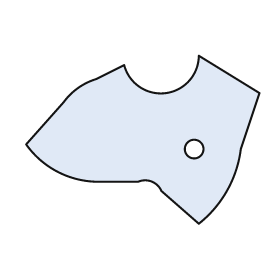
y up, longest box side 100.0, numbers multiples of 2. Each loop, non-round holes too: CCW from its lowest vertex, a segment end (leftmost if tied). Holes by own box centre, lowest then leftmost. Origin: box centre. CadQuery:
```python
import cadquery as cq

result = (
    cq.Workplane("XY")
    .moveTo(24.0, -36.0)
    .threePointArc((36.0, -22.0), (42.0, -4.0))
    .lineTo(50.0, 20.0)
    .lineTo(24.0, 36.0)
    .threePointArc((10.0, 20.0), (-8.0, 32.0))
    .lineTo(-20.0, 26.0)
    .threePointArc((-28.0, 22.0), (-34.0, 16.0))
    .lineTo(-50.0, -2.0)
    .threePointArc((-36.0, -14.0), (-18.0, -18.0))
    .lineTo(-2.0, -18.0)
    .threePointArc((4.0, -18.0), (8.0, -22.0))
    .close()
    .moveTo(22.0, -4.0)
    .circle(4.0)
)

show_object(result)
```